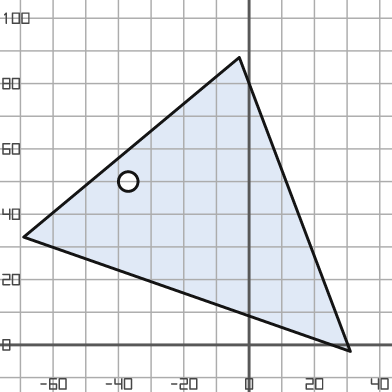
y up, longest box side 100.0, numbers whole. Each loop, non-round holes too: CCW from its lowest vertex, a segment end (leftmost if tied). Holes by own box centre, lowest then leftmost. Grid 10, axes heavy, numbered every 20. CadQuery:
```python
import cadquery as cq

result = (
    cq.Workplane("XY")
    .moveTo(31.0, -2.0)
    .lineTo(-3.0, 88.0)
    .lineTo(-69.0, 33.0)
    .close()
    .moveTo(-37.0, 50.0)
    .circle(3.0)
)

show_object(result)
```